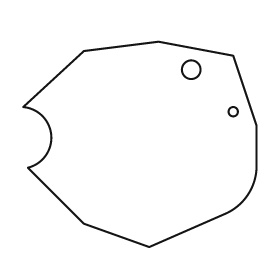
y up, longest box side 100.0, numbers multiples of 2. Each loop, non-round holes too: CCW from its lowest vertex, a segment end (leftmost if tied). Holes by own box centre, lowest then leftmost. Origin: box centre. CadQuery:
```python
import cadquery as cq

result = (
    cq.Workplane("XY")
    .moveTo(4.0, -44.0)
    .lineTo(36.0, -30.0)
    .threePointArc((46.0, -22.0), (50.0, -10.0))
    .lineTo(50.0, 8.0)
    .lineTo(40.0, 38.0)
    .lineTo(8.0, 44.0)
    .lineTo(-24.0, 40.0)
    .lineTo(-50.0, 16.0)
    .threePointArc((-38.0, 4.0), (-48.0, -10.0))
    .lineTo(-24.0, -34.0)
    .close()
    .moveTo(40.0, 14.0)
    .circle(2.0)
    .moveTo(22.0, 32.0)
    .circle(4.0)
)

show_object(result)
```